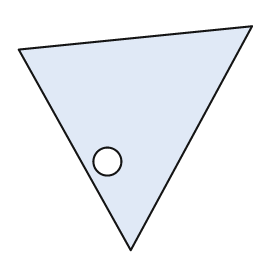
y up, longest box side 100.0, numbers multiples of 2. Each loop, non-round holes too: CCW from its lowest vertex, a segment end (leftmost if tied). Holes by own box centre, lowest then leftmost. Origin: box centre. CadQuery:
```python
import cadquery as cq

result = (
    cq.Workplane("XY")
    .moveTo(-2.0, -48.0)
    .lineTo(50.0, 48.0)
    .lineTo(-50.0, 38.0)
    .close()
    .moveTo(-12.0, -10.0)
    .circle(6.0)
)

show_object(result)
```